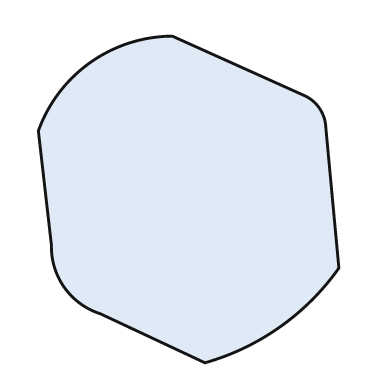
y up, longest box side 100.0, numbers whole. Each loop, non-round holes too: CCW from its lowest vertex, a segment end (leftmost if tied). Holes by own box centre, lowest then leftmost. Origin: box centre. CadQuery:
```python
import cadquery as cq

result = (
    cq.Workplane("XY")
    .moveTo(5.0, -50.0)
    .threePointArc((28.0, -39.0), (46.0, -21.0))
    .lineTo(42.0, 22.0)
    .threePointArc((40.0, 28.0), (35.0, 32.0))
    .lineTo(-5.0, 50.0)
    .threePointArc((-30.0, 42.0), (-46.0, 21.0))
    .lineTo(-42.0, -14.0)
    .threePointArc((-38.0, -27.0), (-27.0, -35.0))
    .close()
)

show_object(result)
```